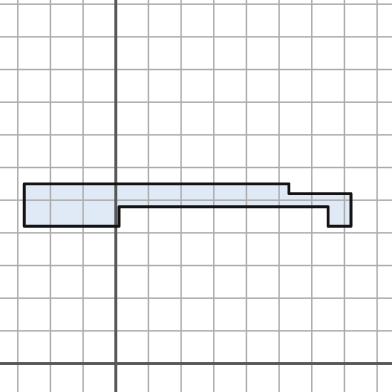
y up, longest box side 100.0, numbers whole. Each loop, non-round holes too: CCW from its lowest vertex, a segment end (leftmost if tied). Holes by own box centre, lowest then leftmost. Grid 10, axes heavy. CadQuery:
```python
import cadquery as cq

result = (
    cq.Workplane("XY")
    .moveTo(-28.0, 42.0)
    .lineTo(1.0, 42.0)
    .lineTo(1.0, 48.0)
    .lineTo(65.0, 48.0)
    .lineTo(65.0, 42.0)
    .lineTo(72.0, 42.0)
    .lineTo(72.0, 52.0)
    .lineTo(53.0, 52.0)
    .lineTo(53.0, 55.0)
    .lineTo(-28.0, 55.0)
    .close()
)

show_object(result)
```